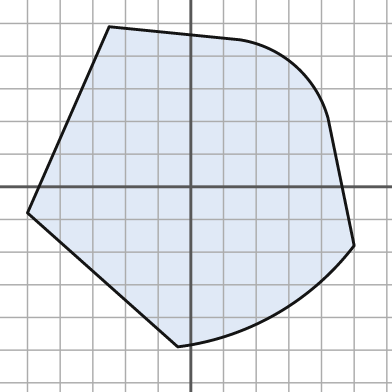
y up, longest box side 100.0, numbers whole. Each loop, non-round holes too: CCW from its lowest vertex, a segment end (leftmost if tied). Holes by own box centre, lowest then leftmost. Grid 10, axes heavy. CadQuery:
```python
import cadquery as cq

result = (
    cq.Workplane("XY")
    .moveTo(-4.0, -49.0)
    .threePointArc((26.0, -39.0), (50.0, -18.0))
    .lineTo(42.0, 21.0)
    .threePointArc((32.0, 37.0), (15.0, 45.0))
    .lineTo(-25.0, 49.0)
    .lineTo(-50.0, -8.0)
    .close()
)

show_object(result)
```